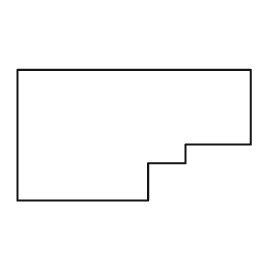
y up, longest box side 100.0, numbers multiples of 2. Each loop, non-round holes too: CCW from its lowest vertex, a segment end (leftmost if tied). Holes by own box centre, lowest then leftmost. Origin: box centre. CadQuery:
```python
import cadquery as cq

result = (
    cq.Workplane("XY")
    .moveTo(-50.0, -28.0)
    .lineTo(6.0, -28.0)
    .lineTo(6.0, -12.0)
    .lineTo(22.0, -12.0)
    .lineTo(22.0, -4.0)
    .lineTo(50.0, -4.0)
    .lineTo(50.0, 28.0)
    .lineTo(-50.0, 28.0)
    .close()
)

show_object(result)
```